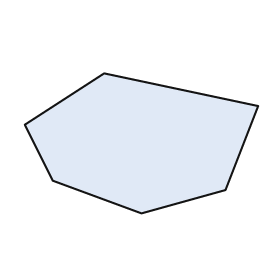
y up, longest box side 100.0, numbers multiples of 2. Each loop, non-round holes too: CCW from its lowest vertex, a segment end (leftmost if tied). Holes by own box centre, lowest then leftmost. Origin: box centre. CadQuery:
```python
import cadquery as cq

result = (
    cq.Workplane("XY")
    .moveTo(0.0, -30.0)
    .lineTo(36.0, -20.0)
    .lineTo(50.0, 16.0)
    .lineTo(-16.0, 30.0)
    .lineTo(-50.0, 8.0)
    .lineTo(-38.0, -16.0)
    .close()
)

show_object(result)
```